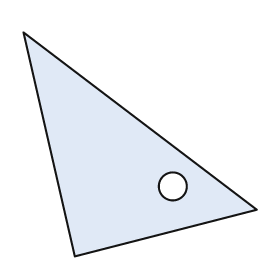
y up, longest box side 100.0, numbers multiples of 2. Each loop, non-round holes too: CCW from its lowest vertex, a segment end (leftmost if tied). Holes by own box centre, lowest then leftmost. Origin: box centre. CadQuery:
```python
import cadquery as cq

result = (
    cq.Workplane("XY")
    .moveTo(-28.0, -48.0)
    .lineTo(50.0, -28.0)
    .lineTo(-50.0, 48.0)
    .close()
    .moveTo(14.0, -18.0)
    .circle(6.0)
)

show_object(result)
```